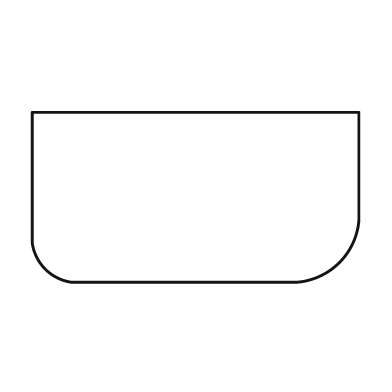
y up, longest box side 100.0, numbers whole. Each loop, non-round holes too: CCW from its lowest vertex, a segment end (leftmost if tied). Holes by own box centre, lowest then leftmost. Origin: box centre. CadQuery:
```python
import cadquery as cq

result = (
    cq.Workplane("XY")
    .moveTo(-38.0, -26.0)
    .lineTo(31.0, -26.0)
    .threePointArc((44.0, -20.0), (50.0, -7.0))
    .lineTo(50.0, 26.0)
    .lineTo(-50.0, 26.0)
    .lineTo(-50.0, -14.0)
    .threePointArc((-46.0, -22.0), (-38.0, -26.0))
    .close()
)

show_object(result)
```